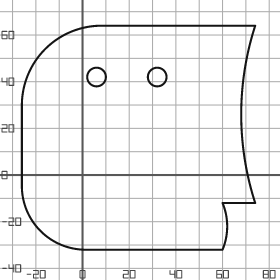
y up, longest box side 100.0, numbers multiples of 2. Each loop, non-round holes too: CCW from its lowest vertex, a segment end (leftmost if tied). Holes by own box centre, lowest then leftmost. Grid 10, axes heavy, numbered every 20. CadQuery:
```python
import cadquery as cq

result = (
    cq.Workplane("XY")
    .moveTo(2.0, -32.0)
    .lineTo(60.0, -32.0)
    .threePointArc((62.0, -22.0), (60.0, -12.0))
    .lineTo(74.0, -12.0)
    .threePointArc((68.0, 26.0), (74.0, 64.0))
    .lineTo(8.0, 64.0)
    .threePointArc((-16.0, 54.0), (-26.0, 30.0))
    .lineTo(-26.0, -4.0)
    .threePointArc((-18.0, -24.0), (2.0, -32.0))
    .close()
    .moveTo(6.0, 42.0)
    .circle(4.0)
    .moveTo(32.0, 42.0)
    .circle(4.0)
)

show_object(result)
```